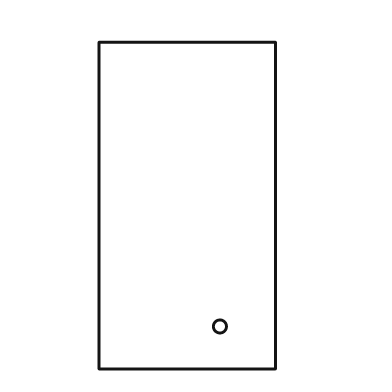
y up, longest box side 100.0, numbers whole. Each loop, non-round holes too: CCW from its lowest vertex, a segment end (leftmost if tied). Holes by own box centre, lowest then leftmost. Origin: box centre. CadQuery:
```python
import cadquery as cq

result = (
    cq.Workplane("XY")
    .moveTo(-27.0, -50.0)
    .lineTo(27.0, -50.0)
    .lineTo(27.0, 50.0)
    .lineTo(-27.0, 50.0)
    .close()
    .moveTo(10.0, -37.0)
    .circle(2.0)
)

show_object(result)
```